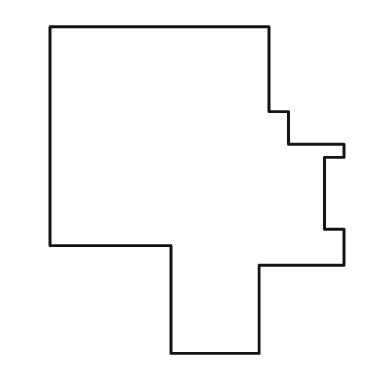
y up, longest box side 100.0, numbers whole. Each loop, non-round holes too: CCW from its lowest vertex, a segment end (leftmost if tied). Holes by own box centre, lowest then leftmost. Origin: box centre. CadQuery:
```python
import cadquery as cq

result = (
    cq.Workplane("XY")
    .moveTo(-8.0, -50.0)
    .lineTo(19.0, -50.0)
    .lineTo(19.0, -23.0)
    .lineTo(45.0, -23.0)
    .lineTo(45.0, -12.0)
    .lineTo(39.0, -12.0)
    .lineTo(39.0, 10.0)
    .lineTo(45.0, 10.0)
    .lineTo(45.0, 14.0)
    .lineTo(28.0, 14.0)
    .lineTo(28.0, 24.0)
    .lineTo(22.0, 24.0)
    .lineTo(22.0, 50.0)
    .lineTo(-45.0, 50.0)
    .lineTo(-45.0, -17.0)
    .lineTo(-8.0, -17.0)
    .close()
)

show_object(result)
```